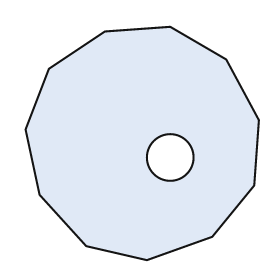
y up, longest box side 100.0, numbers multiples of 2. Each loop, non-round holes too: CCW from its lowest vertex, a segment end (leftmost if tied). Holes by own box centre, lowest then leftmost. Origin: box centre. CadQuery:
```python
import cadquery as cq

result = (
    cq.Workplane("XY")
    .moveTo(2.0, -50.0)
    .lineTo(30.0, -40.0)
    .lineTo(48.0, -18.0)
    .lineTo(50.0, 10.0)
    .lineTo(36.0, 36.0)
    .lineTo(12.0, 50.0)
    .lineTo(-16.0, 48.0)
    .lineTo(-40.0, 32.0)
    .lineTo(-50.0, 6.0)
    .lineTo(-44.0, -22.0)
    .lineTo(-24.0, -44.0)
    .close()
    .moveTo(12.0, -6.0)
    .circle(10.0)
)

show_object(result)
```